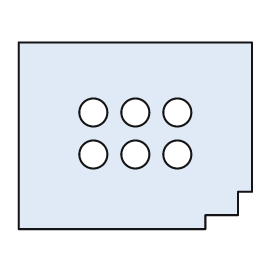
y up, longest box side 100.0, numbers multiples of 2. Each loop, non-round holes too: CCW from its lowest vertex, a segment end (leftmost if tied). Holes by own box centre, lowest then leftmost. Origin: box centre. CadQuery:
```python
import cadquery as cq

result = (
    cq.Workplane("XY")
    .moveTo(-50.0, -40.0)
    .lineTo(30.0, -40.0)
    .lineTo(30.0, -34.0)
    .lineTo(44.0, -34.0)
    .lineTo(44.0, -24.0)
    .lineTo(50.0, -24.0)
    .lineTo(50.0, 40.0)
    .lineTo(-50.0, 40.0)
    .close()
    .moveTo(-18.0, -8.0)
    .circle(6.0)
    .moveTo(0.0, -8.0)
    .circle(6.0)
    .moveTo(18.0, -8.0)
    .circle(6.0)
    .moveTo(-18.0, 10.0)
    .circle(6.0)
    .moveTo(0.0, 10.0)
    .circle(6.0)
    .moveTo(18.0, 10.0)
    .circle(6.0)
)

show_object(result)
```